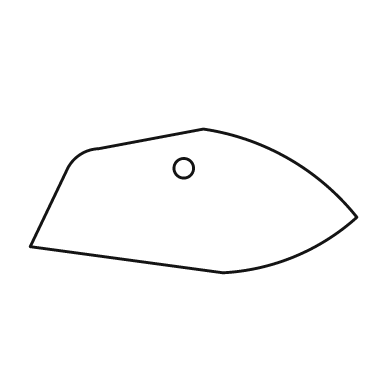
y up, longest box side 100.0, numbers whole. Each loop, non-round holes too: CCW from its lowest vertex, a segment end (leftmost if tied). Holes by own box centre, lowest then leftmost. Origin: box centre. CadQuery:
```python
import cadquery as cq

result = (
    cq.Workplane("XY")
    .moveTo(9.0, -22.0)
    .threePointArc((31.0, -17.0), (50.0, -5.0))
    .threePointArc((29.0, 13.0), (3.0, 22.0))
    .lineTo(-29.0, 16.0)
    .threePointArc((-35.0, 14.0), (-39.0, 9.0))
    .lineTo(-50.0, -14.0)
    .close()
    .moveTo(-3.0, 10.0)
    .circle(3.0)
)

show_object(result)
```